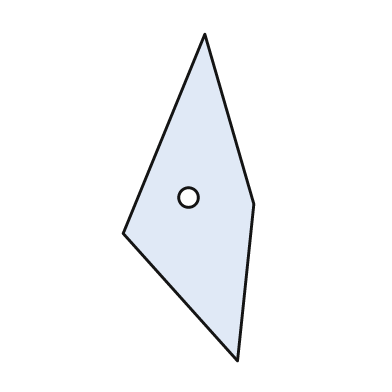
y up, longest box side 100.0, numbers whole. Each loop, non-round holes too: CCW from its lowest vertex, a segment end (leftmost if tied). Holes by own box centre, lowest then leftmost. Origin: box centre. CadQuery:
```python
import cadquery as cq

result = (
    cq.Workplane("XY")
    .moveTo(15.0, -50.0)
    .lineTo(20.0, -2.0)
    .lineTo(5.0, 50.0)
    .lineTo(-20.0, -11.0)
    .close()
    .moveTo(0.0, 0.0)
    .circle(3.0)
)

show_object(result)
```